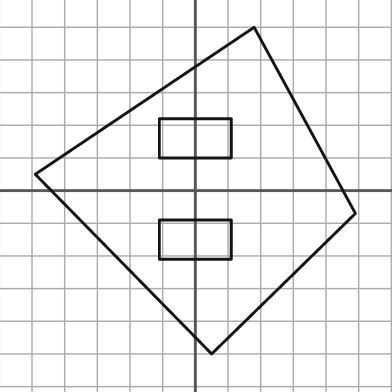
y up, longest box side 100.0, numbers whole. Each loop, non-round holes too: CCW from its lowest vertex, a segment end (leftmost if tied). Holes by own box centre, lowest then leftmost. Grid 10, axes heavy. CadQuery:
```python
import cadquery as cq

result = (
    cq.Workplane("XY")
    .moveTo(5.0, -50.0)
    .lineTo(49.0, -7.0)
    .lineTo(18.0, 50.0)
    .lineTo(-49.0, 5.0)
    .close()
    .moveTo(-11.0, -21.0)
    .lineTo(11.0, -21.0)
    .lineTo(11.0, -9.0)
    .lineTo(-11.0, -9.0)
    .close()
    .moveTo(-11.0, 10.0)
    .lineTo(11.0, 10.0)
    .lineTo(11.0, 22.0)
    .lineTo(-11.0, 22.0)
    .close()
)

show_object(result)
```